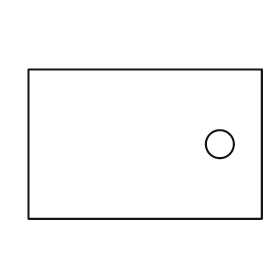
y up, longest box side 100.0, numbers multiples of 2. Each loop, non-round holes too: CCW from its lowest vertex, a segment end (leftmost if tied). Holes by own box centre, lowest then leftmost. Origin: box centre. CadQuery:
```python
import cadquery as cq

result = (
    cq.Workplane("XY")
    .moveTo(-50.0, -32.0)
    .lineTo(50.0, -32.0)
    .lineTo(50.0, 32.0)
    .lineTo(-50.0, 32.0)
    .close()
    .moveTo(32.0, 0.0)
    .circle(6.0)
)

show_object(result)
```